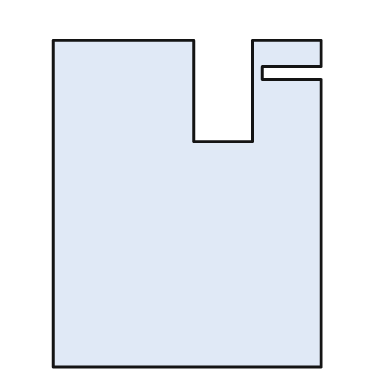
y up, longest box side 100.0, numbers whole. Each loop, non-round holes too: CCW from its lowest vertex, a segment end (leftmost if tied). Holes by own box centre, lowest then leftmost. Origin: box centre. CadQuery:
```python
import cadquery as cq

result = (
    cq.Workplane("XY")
    .moveTo(-41.0, -50.0)
    .lineTo(41.0, -50.0)
    .lineTo(41.0, 38.0)
    .lineTo(23.0, 38.0)
    .lineTo(23.0, 42.0)
    .lineTo(41.0, 42.0)
    .lineTo(41.0, 50.0)
    .lineTo(20.0, 50.0)
    .lineTo(20.0, 19.0)
    .lineTo(2.0, 19.0)
    .lineTo(2.0, 50.0)
    .lineTo(-41.0, 50.0)
    .close()
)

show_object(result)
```